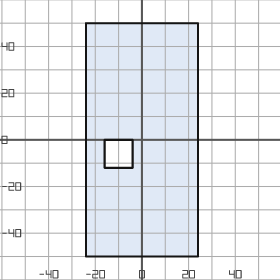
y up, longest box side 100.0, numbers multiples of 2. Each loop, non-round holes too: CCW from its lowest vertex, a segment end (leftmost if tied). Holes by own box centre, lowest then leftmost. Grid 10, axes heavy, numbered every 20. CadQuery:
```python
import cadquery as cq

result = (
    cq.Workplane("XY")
    .moveTo(-24.0, -50.0)
    .lineTo(24.0, -50.0)
    .lineTo(24.0, 50.0)
    .lineTo(-24.0, 50.0)
    .close()
    .moveTo(-16.0, -12.0)
    .lineTo(-4.0, -12.0)
    .lineTo(-4.0, 0.0)
    .lineTo(-16.0, 0.0)
    .close()
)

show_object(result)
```